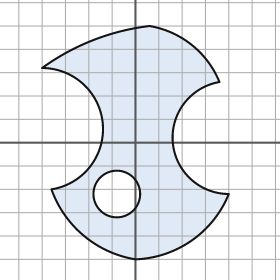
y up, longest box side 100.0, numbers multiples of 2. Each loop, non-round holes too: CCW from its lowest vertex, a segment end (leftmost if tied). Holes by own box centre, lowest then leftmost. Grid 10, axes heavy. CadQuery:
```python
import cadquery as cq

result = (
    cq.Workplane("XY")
    .moveTo(0.0, -50.0)
    .threePointArc((24.0, -42.0), (40.0, -22.0))
    .threePointArc((16.0, 0.0), (36.0, 26.0))
    .threePointArc((24.0, 42.0), (6.0, 50.0))
    .threePointArc((-18.0, 44.0), (-40.0, 32.0))
    .threePointArc((-14.0, 8.0), (-36.0, -20.0))
    .threePointArc((-22.0, -40.0), (0.0, -50.0))
    .close()
    .moveTo(-8.0, -22.0)
    .circle(10.0)
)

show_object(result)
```